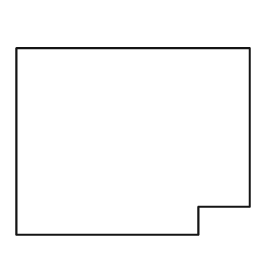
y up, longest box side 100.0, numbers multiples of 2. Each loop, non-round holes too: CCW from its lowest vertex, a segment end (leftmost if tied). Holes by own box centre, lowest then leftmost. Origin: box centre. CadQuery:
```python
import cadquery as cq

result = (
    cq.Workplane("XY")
    .moveTo(-50.0, -40.0)
    .lineTo(28.0, -40.0)
    .lineTo(28.0, -28.0)
    .lineTo(50.0, -28.0)
    .lineTo(50.0, 40.0)
    .lineTo(-50.0, 40.0)
    .close()
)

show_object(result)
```